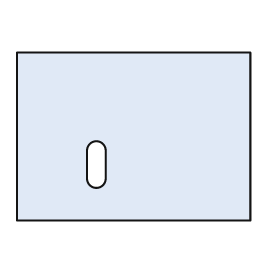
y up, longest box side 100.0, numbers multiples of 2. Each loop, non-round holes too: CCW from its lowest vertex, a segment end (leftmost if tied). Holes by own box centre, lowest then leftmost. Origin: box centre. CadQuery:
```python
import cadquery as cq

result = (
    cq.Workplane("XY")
    .moveTo(-50.0, -36.0)
    .lineTo(50.0, -36.0)
    .lineTo(50.0, 36.0)
    .lineTo(-50.0, 36.0)
    .close()
    .moveTo(-20.0, -18.0)
    .threePointArc((-16.0, -22.0), (-12.0, -18.0))
    .lineTo(-12.0, -6.0)
    .threePointArc((-16.0, -2.0), (-20.0, -6.0))
    .close()
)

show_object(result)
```